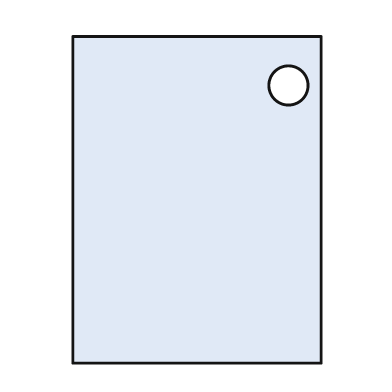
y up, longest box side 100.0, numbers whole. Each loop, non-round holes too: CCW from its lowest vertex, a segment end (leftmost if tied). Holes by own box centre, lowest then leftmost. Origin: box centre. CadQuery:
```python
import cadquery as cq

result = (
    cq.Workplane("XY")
    .moveTo(-38.0, -50.0)
    .lineTo(38.0, -50.0)
    .lineTo(38.0, 50.0)
    .lineTo(-38.0, 50.0)
    .close()
    .moveTo(28.0, 35.0)
    .circle(6.0)
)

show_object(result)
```